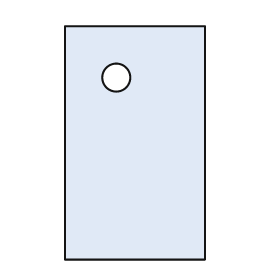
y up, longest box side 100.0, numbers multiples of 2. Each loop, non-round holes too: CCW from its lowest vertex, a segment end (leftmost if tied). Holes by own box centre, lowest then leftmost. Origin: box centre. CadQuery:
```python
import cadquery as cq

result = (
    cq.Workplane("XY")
    .moveTo(-30.0, -50.0)
    .lineTo(30.0, -50.0)
    .lineTo(30.0, 50.0)
    .lineTo(-30.0, 50.0)
    .close()
    .moveTo(-8.0, 28.0)
    .circle(6.0)
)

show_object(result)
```